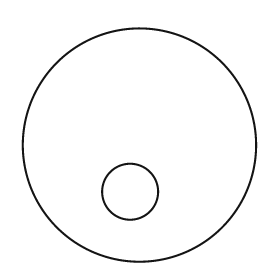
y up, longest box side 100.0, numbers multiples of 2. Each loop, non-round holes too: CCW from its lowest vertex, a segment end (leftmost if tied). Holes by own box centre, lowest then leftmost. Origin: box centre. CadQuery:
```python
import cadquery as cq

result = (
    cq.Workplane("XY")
    .moveTo(0.0, 0.0)
    .circle(50.0)
    .moveTo(-4.0, -20.0)
    .circle(12.0)
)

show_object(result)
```